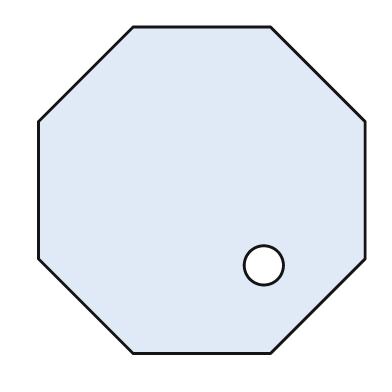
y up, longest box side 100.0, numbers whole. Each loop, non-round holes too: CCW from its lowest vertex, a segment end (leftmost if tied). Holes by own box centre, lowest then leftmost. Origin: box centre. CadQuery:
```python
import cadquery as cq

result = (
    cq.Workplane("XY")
    .moveTo(-21.0, -50.0)
    .lineTo(21.0, -50.0)
    .lineTo(50.0, -21.0)
    .lineTo(50.0, 21.0)
    .lineTo(21.0, 50.0)
    .lineTo(-21.0, 50.0)
    .lineTo(-50.0, 21.0)
    .lineTo(-50.0, -21.0)
    .close()
    .moveTo(19.0, -23.0)
    .circle(6.0)
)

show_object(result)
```